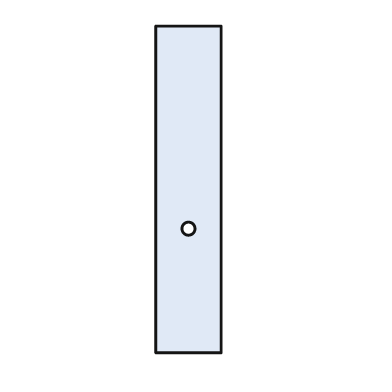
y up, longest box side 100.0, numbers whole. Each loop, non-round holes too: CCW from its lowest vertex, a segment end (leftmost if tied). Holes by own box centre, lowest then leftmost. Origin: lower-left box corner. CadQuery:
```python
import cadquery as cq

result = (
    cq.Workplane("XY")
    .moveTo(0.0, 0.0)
    .lineTo(20.0, 0.0)
    .lineTo(20.0, 100.0)
    .lineTo(0.0, 100.0)
    .close()
    .moveTo(10.0, 38.0)
    .circle(2.0)
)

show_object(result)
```